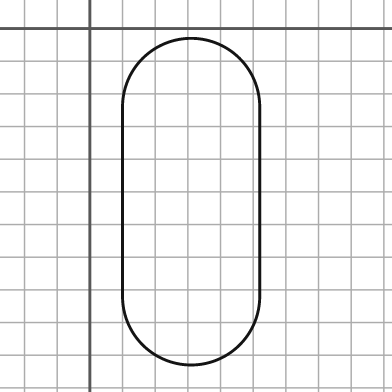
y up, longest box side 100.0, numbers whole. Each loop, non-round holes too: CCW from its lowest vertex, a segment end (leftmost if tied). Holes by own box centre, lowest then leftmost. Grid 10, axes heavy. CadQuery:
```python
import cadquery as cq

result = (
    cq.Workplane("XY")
    .moveTo(10.0, -82.0)
    .threePointArc((31.0, -103.0), (52.0, -82.0))
    .lineTo(52.0, -24.0)
    .threePointArc((31.0, -3.0), (10.0, -24.0))
    .close()
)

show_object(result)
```